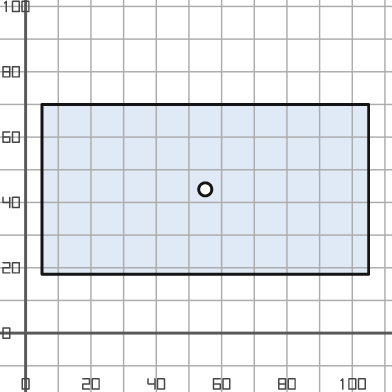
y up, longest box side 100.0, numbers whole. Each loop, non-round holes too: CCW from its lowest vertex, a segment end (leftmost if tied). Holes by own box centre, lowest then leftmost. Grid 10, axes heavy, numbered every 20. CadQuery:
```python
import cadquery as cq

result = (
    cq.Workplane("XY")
    .moveTo(5.0, 18.0)
    .lineTo(105.0, 18.0)
    .lineTo(105.0, 70.0)
    .lineTo(5.0, 70.0)
    .close()
    .moveTo(55.0, 44.0)
    .circle(2.0)
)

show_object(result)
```